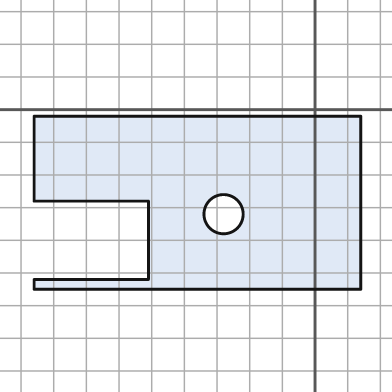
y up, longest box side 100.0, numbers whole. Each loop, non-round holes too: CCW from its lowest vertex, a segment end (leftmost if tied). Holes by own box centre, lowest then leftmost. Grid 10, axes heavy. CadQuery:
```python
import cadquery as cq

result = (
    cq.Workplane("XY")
    .moveTo(-86.0, -55.0)
    .lineTo(14.0, -55.0)
    .lineTo(14.0, -2.0)
    .lineTo(-86.0, -2.0)
    .lineTo(-86.0, -28.0)
    .lineTo(-51.0, -28.0)
    .lineTo(-51.0, -52.0)
    .lineTo(-86.0, -52.0)
    .close()
    .moveTo(-28.0, -32.0)
    .circle(6.0)
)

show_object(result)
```